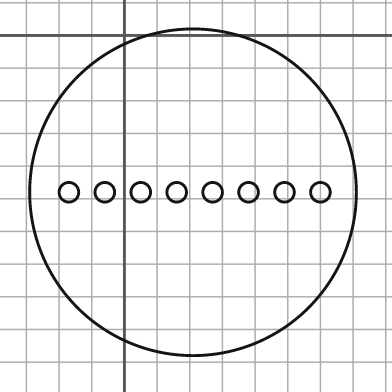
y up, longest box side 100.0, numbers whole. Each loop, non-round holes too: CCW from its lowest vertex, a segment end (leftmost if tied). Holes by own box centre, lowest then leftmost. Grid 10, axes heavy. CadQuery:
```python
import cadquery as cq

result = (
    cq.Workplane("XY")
    .moveTo(21.0, -48.0)
    .circle(50.0)
    .moveTo(-17.0, -48.0)
    .circle(3.0)
    .moveTo(-6.0, -48.0)
    .circle(3.0)
    .moveTo(5.0, -48.0)
    .circle(3.0)
    .moveTo(16.0, -48.0)
    .circle(3.0)
    .moveTo(27.0, -48.0)
    .circle(3.0)
    .moveTo(38.0, -48.0)
    .circle(3.0)
    .moveTo(49.0, -48.0)
    .circle(3.0)
    .moveTo(60.0, -48.0)
    .circle(3.0)
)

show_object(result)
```